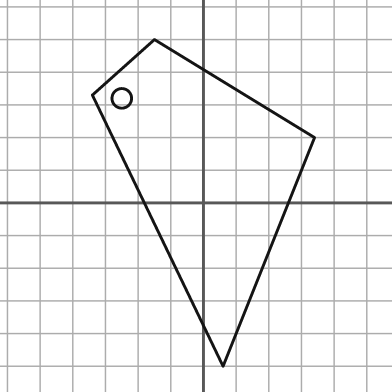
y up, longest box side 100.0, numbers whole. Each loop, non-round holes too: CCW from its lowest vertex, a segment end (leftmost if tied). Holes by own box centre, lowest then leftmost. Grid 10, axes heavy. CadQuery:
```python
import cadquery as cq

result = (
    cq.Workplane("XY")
    .moveTo(6.0, -50.0)
    .lineTo(34.0, 20.0)
    .lineTo(-15.0, 50.0)
    .lineTo(-34.0, 33.0)
    .close()
    .moveTo(-25.0, 32.0)
    .circle(3.0)
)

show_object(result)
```